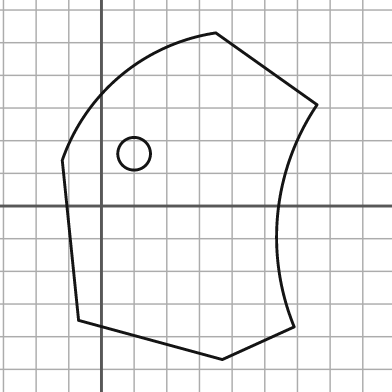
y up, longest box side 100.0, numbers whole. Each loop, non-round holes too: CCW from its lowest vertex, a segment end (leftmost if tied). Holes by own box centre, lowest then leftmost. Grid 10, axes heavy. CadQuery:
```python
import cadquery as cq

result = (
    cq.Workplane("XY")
    .moveTo(37.0, -47.0)
    .lineTo(59.0, -37.0)
    .threePointArc((54.0, -2.0), (66.0, 31.0))
    .lineTo(35.0, 53.0)
    .threePointArc((6.0, 40.0), (-12.0, 14.0))
    .lineTo(-7.0, -35.0)
    .close()
    .moveTo(10.0, 16.0)
    .circle(5.0)
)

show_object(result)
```